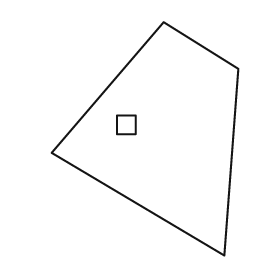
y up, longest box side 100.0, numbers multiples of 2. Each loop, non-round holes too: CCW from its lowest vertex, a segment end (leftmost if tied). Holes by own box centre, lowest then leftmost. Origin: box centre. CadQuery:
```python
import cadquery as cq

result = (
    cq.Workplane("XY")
    .moveTo(34.0, -50.0)
    .lineTo(40.0, 30.0)
    .lineTo(8.0, 50.0)
    .lineTo(-40.0, -6.0)
    .close()
    .moveTo(-12.0, 2.0)
    .lineTo(-4.0, 2.0)
    .lineTo(-4.0, 10.0)
    .lineTo(-12.0, 10.0)
    .close()
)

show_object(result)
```